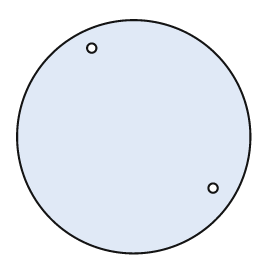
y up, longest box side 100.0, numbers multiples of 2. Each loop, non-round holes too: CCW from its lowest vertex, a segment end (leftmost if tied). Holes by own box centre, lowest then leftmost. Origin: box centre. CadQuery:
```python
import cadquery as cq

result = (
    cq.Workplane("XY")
    .moveTo(0.0, 0.0)
    .circle(50.0)
    .moveTo(34.0, -22.0)
    .circle(2.0)
    .moveTo(-18.0, 38.0)
    .circle(2.0)
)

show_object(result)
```